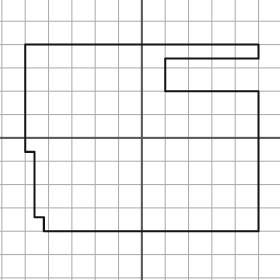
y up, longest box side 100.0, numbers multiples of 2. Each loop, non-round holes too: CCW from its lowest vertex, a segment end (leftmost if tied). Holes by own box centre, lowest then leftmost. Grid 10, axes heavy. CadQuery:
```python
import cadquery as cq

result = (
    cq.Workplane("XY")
    .moveTo(-42.0, -40.0)
    .lineTo(50.0, -40.0)
    .lineTo(50.0, 20.0)
    .lineTo(10.0, 20.0)
    .lineTo(10.0, 34.0)
    .lineTo(50.0, 34.0)
    .lineTo(50.0, 40.0)
    .lineTo(-50.0, 40.0)
    .lineTo(-50.0, -6.0)
    .lineTo(-46.0, -6.0)
    .lineTo(-46.0, -34.0)
    .lineTo(-42.0, -34.0)
    .close()
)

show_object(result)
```